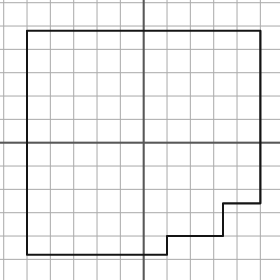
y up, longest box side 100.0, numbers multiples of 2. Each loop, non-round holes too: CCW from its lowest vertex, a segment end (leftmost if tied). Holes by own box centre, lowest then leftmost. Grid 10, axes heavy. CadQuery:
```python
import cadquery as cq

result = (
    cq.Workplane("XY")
    .moveTo(-50.0, -48.0)
    .lineTo(10.0, -48.0)
    .lineTo(10.0, -40.0)
    .lineTo(34.0, -40.0)
    .lineTo(34.0, -26.0)
    .lineTo(50.0, -26.0)
    .lineTo(50.0, 48.0)
    .lineTo(-50.0, 48.0)
    .close()
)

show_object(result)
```